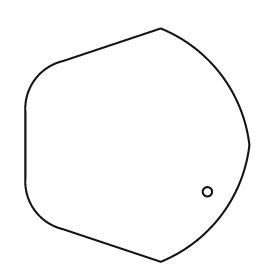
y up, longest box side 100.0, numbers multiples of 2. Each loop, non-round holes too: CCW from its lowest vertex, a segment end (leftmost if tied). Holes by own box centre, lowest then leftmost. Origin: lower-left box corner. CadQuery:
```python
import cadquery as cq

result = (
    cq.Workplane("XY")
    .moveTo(58.0, 0.0)
    .threePointArc((84.0, 20.0), (96.0, 50.0))
    .threePointArc((84.0, 80.0), (58.0, 100.0))
    .lineTo(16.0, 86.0)
    .threePointArc((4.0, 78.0), (0.0, 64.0))
    .lineTo(0.0, 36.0)
    .threePointArc((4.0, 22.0), (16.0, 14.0))
    .close()
    .moveTo(78.0, 30.0)
    .circle(2.0)
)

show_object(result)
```